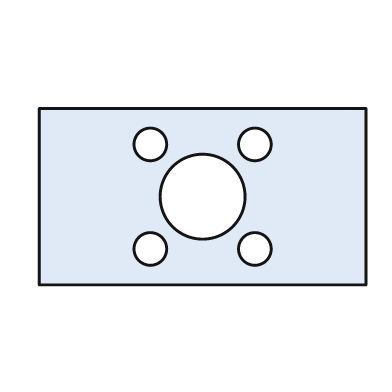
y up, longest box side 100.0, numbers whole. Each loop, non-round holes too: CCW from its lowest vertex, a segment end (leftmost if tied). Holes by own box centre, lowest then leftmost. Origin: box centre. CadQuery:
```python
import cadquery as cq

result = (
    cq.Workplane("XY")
    .moveTo(-50.0, -27.0)
    .lineTo(50.0, -27.0)
    .lineTo(50.0, 27.0)
    .lineTo(-50.0, 27.0)
    .close()
    .moveTo(-16.0, -16.0)
    .circle(5.0)
    .moveTo(16.0, -16.0)
    .circle(5.0)
    .moveTo(0.0, 0.0)
    .circle(13.0)
    .moveTo(-16.0, 16.0)
    .circle(5.0)
    .moveTo(16.0, 16.0)
    .circle(5.0)
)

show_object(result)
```